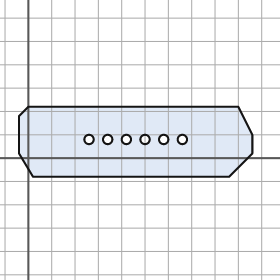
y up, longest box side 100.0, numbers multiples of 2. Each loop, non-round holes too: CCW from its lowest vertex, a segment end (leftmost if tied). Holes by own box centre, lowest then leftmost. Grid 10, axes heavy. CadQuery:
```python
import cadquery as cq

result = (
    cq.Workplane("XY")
    .moveTo(2.0, -8.0)
    .lineTo(86.0, -8.0)
    .lineTo(96.0, 2.0)
    .lineTo(96.0, 10.0)
    .lineTo(90.0, 22.0)
    .lineTo(0.0, 22.0)
    .lineTo(-4.0, 18.0)
    .lineTo(-4.0, 2.0)
    .close()
    .moveTo(26.0, 8.0)
    .circle(2.0)
    .moveTo(34.0, 8.0)
    .circle(2.0)
    .moveTo(42.0, 8.0)
    .circle(2.0)
    .moveTo(50.0, 8.0)
    .circle(2.0)
    .moveTo(58.0, 8.0)
    .circle(2.0)
    .moveTo(66.0, 8.0)
    .circle(2.0)
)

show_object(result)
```